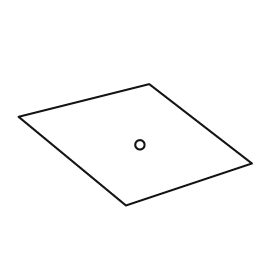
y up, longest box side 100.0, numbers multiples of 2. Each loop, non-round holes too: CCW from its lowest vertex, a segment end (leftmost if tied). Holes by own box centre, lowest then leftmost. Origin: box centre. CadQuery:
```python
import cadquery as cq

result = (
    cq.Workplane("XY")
    .moveTo(-4.0, -26.0)
    .lineTo(50.0, -8.0)
    .lineTo(6.0, 26.0)
    .lineTo(-50.0, 12.0)
    .close()
    .moveTo(2.0, 0.0)
    .circle(2.0)
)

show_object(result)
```